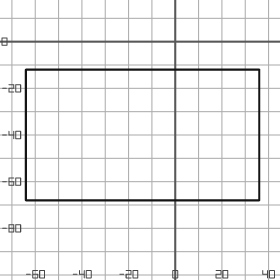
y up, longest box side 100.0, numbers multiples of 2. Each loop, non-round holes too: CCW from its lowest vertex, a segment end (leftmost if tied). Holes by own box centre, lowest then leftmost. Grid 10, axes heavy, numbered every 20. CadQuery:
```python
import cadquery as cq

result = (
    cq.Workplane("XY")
    .moveTo(-64.0, -68.0)
    .lineTo(36.0, -68.0)
    .lineTo(36.0, -12.0)
    .lineTo(-64.0, -12.0)
    .close()
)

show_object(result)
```